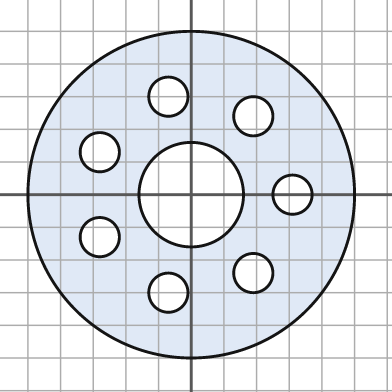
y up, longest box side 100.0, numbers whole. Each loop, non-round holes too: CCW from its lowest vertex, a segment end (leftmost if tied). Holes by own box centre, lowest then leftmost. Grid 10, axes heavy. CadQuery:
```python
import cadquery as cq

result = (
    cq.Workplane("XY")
    .moveTo(0.0, 0.0)
    .circle(50.0)
    .moveTo(-7.0, -30.0)
    .circle(6.0)
    .moveTo(19.0, -24.0)
    .circle(6.0)
    .moveTo(-28.0, -13.0)
    .circle(6.0)
    .moveTo(0.0, 0.0)
    .circle(16.0)
    .moveTo(31.0, 0.0)
    .circle(6.0)
    .moveTo(-28.0, 13.0)
    .circle(6.0)
    .moveTo(19.0, 24.0)
    .circle(6.0)
    .moveTo(-7.0, 30.0)
    .circle(6.0)
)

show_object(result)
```